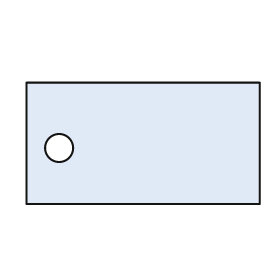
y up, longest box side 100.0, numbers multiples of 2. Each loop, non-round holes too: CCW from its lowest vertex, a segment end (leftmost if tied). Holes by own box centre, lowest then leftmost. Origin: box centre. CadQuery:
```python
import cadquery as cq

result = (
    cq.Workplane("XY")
    .moveTo(-50.0, -26.0)
    .lineTo(50.0, -26.0)
    .lineTo(50.0, 26.0)
    .lineTo(-50.0, 26.0)
    .close()
    .moveTo(-36.0, -2.0)
    .circle(6.0)
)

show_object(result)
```